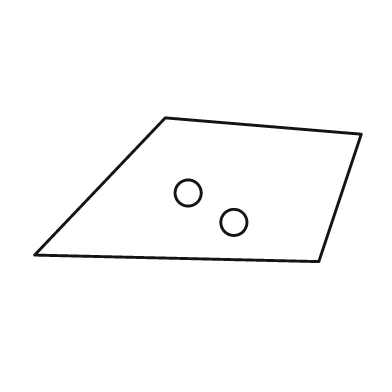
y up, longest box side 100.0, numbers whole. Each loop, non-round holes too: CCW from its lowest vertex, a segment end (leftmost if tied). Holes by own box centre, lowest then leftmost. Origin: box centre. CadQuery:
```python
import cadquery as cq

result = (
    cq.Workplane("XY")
    .moveTo(37.0, -22.0)
    .lineTo(50.0, 17.0)
    .lineTo(-10.0, 22.0)
    .lineTo(-50.0, -20.0)
    .close()
    .moveTo(11.0, -10.0)
    .circle(4.0)
    .moveTo(-3.0, -1.0)
    .circle(4.0)
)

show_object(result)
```